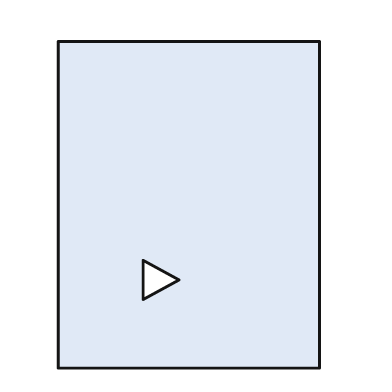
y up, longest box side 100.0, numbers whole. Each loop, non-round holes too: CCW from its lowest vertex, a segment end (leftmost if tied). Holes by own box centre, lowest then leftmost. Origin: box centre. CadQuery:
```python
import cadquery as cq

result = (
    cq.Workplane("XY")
    .moveTo(-40.0, -50.0)
    .lineTo(40.0, -50.0)
    .lineTo(40.0, 50.0)
    .lineTo(-40.0, 50.0)
    .close()
    .moveTo(-14.0, -29.0)
    .lineTo(-3.0, -23.0)
    .lineTo(-14.0, -17.0)
    .close()
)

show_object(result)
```